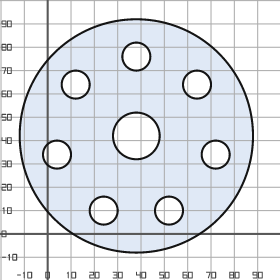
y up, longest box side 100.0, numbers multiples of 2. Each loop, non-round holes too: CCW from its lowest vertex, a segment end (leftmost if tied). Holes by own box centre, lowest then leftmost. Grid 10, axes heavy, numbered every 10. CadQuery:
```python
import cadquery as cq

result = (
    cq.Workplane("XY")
    .moveTo(38.0, 42.0)
    .circle(50.0)
    .moveTo(24.0, 10.0)
    .circle(6.0)
    .moveTo(52.0, 10.0)
    .circle(6.0)
    .moveTo(4.0, 34.0)
    .circle(6.0)
    .moveTo(72.0, 34.0)
    .circle(6.0)
    .moveTo(38.0, 42.0)
    .circle(10.0)
    .moveTo(12.0, 64.0)
    .circle(6.0)
    .moveTo(64.0, 64.0)
    .circle(6.0)
    .moveTo(38.0, 76.0)
    .circle(6.0)
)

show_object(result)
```